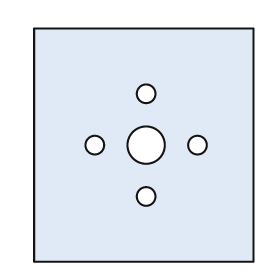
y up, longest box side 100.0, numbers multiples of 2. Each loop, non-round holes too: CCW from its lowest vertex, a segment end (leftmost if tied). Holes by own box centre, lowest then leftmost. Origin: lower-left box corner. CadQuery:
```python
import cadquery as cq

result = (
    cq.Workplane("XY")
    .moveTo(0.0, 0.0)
    .lineTo(94.0, 0.0)
    .lineTo(94.0, 100.0)
    .lineTo(0.0, 100.0)
    .close()
    .moveTo(48.0, 28.0)
    .circle(4.0)
    .moveTo(26.0, 50.0)
    .circle(4.0)
    .moveTo(48.0, 50.0)
    .circle(8.0)
    .moveTo(70.0, 50.0)
    .circle(4.0)
    .moveTo(48.0, 72.0)
    .circle(4.0)
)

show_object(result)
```